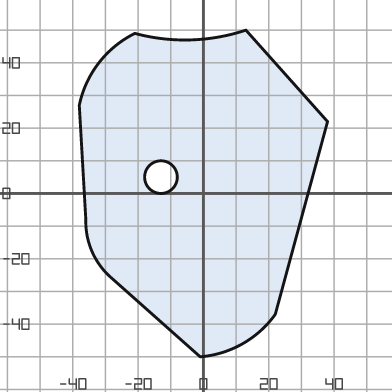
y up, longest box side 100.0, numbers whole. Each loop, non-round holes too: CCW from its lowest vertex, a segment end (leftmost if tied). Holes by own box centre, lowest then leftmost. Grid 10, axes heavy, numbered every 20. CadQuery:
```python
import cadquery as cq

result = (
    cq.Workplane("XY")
    .moveTo(-1.0, -50.0)
    .threePointArc((12.0, -46.0), (22.0, -37.0))
    .lineTo(38.0, 22.0)
    .lineTo(13.0, 50.0)
    .threePointArc((-4.0, 47.0), (-21.0, 49.0))
    .threePointArc((-32.0, 40.0), (-38.0, 27.0))
    .lineTo(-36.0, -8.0)
    .threePointArc((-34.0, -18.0), (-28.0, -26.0))
    .close()
    .moveTo(-13.0, 5.0)
    .circle(5.0)
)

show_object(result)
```